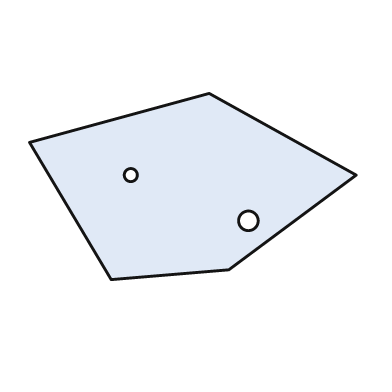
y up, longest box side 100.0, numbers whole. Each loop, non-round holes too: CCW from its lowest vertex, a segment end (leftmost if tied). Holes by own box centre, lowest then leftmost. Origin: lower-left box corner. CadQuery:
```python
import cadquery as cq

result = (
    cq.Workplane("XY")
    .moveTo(25.0, 0.0)
    .lineTo(61.0, 3.0)
    .lineTo(100.0, 32.0)
    .lineTo(55.0, 57.0)
    .lineTo(0.0, 42.0)
    .close()
    .moveTo(67.0, 18.0)
    .circle(3.0)
    .moveTo(31.0, 32.0)
    .circle(2.0)
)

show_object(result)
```